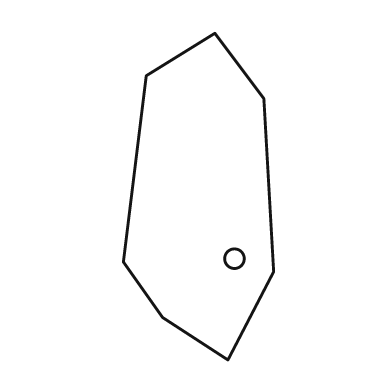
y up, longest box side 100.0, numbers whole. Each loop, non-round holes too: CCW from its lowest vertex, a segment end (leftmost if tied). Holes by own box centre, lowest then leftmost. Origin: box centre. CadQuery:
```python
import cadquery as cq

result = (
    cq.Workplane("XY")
    .moveTo(9.0, -50.0)
    .lineTo(23.0, -23.0)
    .lineTo(20.0, 30.0)
    .lineTo(5.0, 50.0)
    .lineTo(-16.0, 37.0)
    .lineTo(-23.0, -20.0)
    .lineTo(-11.0, -37.0)
    .close()
    .moveTo(11.0, -19.0)
    .circle(3.0)
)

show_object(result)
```